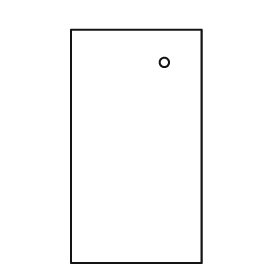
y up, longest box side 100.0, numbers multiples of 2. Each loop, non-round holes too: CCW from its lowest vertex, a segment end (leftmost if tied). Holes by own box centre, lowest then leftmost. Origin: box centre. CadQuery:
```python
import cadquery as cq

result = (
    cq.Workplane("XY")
    .moveTo(-28.0, -50.0)
    .lineTo(28.0, -50.0)
    .lineTo(28.0, 50.0)
    .lineTo(-28.0, 50.0)
    .close()
    .moveTo(12.0, 36.0)
    .circle(2.0)
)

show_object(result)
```